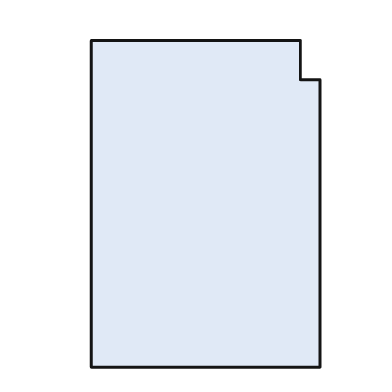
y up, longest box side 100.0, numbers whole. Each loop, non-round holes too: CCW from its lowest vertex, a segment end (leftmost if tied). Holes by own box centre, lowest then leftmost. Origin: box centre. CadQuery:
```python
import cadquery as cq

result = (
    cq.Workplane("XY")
    .moveTo(-35.0, -50.0)
    .lineTo(35.0, -50.0)
    .lineTo(35.0, 38.0)
    .lineTo(29.0, 38.0)
    .lineTo(29.0, 50.0)
    .lineTo(-35.0, 50.0)
    .close()
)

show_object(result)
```